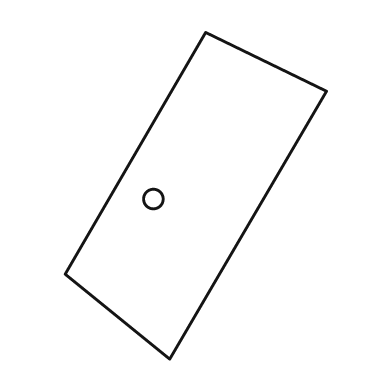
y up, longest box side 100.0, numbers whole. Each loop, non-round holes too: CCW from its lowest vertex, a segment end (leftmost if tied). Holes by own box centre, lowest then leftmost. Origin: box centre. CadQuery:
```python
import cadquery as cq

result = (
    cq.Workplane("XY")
    .moveTo(-8.0, -50.0)
    .lineTo(40.0, 32.0)
    .lineTo(3.0, 50.0)
    .lineTo(-40.0, -24.0)
    .close()
    .moveTo(-13.0, -1.0)
    .circle(3.0)
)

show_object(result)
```